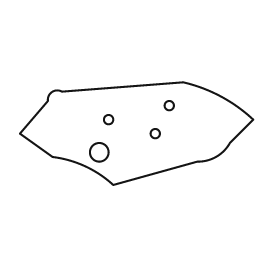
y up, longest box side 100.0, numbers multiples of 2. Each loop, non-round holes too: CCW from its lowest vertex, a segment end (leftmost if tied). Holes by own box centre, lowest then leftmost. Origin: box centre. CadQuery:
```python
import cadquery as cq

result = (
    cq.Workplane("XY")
    .moveTo(-10.0, -22.0)
    .lineTo(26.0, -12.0)
    .threePointArc((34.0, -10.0), (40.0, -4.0))
    .lineTo(50.0, 6.0)
    .threePointArc((36.0, 16.0), (20.0, 22.0))
    .lineTo(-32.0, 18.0)
    .threePointArc((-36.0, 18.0), (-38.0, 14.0))
    .lineTo(-50.0, 0.0)
    .lineTo(-36.0, -10.0)
    .threePointArc((-22.0, -14.0), (-10.0, -22.0))
    .close()
    .moveTo(-16.0, -8.0)
    .circle(4.0)
    .moveTo(8.0, 0.0)
    .circle(2.0)
    .moveTo(-12.0, 6.0)
    .circle(2.0)
    .moveTo(14.0, 12.0)
    .circle(2.0)
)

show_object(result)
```